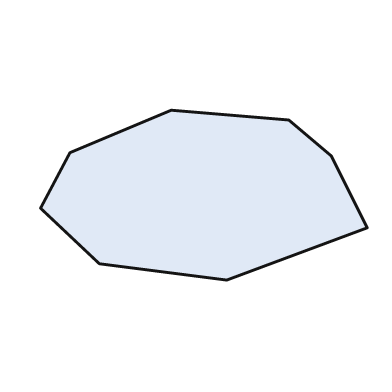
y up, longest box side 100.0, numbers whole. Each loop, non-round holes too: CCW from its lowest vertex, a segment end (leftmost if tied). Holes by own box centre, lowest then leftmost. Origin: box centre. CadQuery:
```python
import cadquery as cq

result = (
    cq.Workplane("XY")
    .moveTo(7.0, -26.0)
    .lineTo(50.0, -10.0)
    .lineTo(39.0, 12.0)
    .lineTo(26.0, 23.0)
    .lineTo(-10.0, 26.0)
    .lineTo(-41.0, 13.0)
    .lineTo(-50.0, -4.0)
    .lineTo(-32.0, -21.0)
    .close()
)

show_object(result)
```